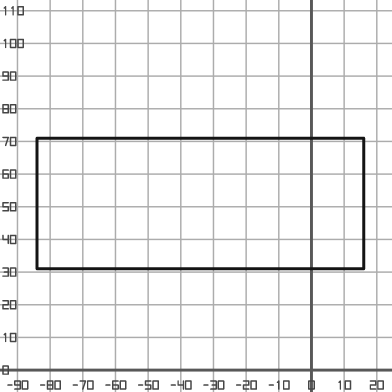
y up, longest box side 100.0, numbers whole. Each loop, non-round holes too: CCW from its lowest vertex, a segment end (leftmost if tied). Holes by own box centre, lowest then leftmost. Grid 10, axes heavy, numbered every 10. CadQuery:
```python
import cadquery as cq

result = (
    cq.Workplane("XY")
    .moveTo(-84.0, 31.0)
    .lineTo(16.0, 31.0)
    .lineTo(16.0, 71.0)
    .lineTo(-84.0, 71.0)
    .close()
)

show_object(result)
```